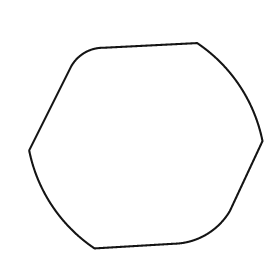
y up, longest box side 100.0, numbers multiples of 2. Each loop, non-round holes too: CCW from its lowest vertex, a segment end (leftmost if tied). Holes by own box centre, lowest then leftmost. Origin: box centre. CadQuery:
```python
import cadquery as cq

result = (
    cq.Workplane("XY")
    .moveTo(-22.0, -44.0)
    .lineTo(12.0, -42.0)
    .threePointArc((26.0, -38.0), (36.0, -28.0))
    .lineTo(50.0, 2.0)
    .threePointArc((40.0, 26.0), (22.0, 44.0))
    .lineTo(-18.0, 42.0)
    .threePointArc((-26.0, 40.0), (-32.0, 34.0))
    .lineTo(-50.0, -2.0)
    .threePointArc((-40.0, -26.0), (-22.0, -44.0))
    .close()
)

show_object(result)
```